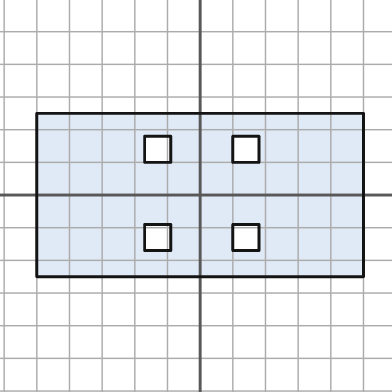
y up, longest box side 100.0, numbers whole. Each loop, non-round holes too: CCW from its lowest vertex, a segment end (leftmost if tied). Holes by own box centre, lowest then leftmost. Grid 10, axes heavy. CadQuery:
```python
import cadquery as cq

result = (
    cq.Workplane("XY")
    .moveTo(-50.0, -25.0)
    .lineTo(50.0, -25.0)
    .lineTo(50.0, 25.0)
    .lineTo(-50.0, 25.0)
    .close()
    .moveTo(-17.0, -17.0)
    .lineTo(-9.0, -17.0)
    .lineTo(-9.0, -9.0)
    .lineTo(-17.0, -9.0)
    .close()
    .moveTo(10.0, -17.0)
    .lineTo(18.0, -17.0)
    .lineTo(18.0, -9.0)
    .lineTo(10.0, -9.0)
    .close()
    .moveTo(-17.0, 10.0)
    .lineTo(-9.0, 10.0)
    .lineTo(-9.0, 18.0)
    .lineTo(-17.0, 18.0)
    .close()
    .moveTo(10.0, 10.0)
    .lineTo(18.0, 10.0)
    .lineTo(18.0, 18.0)
    .lineTo(10.0, 18.0)
    .close()
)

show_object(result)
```